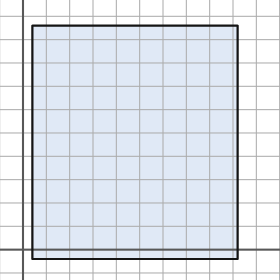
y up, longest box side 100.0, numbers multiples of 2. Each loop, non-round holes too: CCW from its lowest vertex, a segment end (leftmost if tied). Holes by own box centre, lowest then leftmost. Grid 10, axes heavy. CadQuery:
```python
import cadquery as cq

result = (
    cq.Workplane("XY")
    .moveTo(4.0, -4.0)
    .lineTo(92.0, -4.0)
    .lineTo(92.0, 96.0)
    .lineTo(4.0, 96.0)
    .close()
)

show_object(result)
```